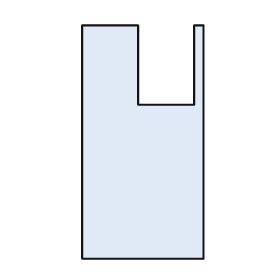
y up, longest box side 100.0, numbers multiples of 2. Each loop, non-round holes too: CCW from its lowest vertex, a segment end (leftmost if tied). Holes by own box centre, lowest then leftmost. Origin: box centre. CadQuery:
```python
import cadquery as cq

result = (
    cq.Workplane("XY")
    .moveTo(-26.0, -50.0)
    .lineTo(26.0, -50.0)
    .lineTo(26.0, 50.0)
    .lineTo(22.0, 50.0)
    .lineTo(22.0, 16.0)
    .lineTo(-2.0, 16.0)
    .lineTo(-2.0, 50.0)
    .lineTo(-26.0, 50.0)
    .close()
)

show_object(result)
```